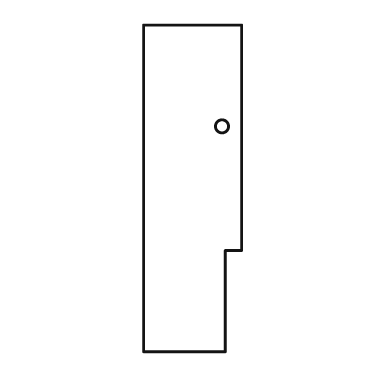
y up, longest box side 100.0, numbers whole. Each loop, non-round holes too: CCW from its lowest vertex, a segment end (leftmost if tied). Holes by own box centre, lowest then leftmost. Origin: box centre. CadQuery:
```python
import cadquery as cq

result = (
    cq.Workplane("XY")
    .moveTo(-15.0, -50.0)
    .lineTo(10.0, -50.0)
    .lineTo(10.0, -19.0)
    .lineTo(15.0, -19.0)
    .lineTo(15.0, 50.0)
    .lineTo(-15.0, 50.0)
    .close()
    .moveTo(9.0, 19.0)
    .circle(2.0)
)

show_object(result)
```